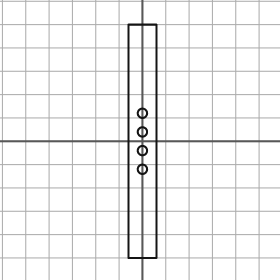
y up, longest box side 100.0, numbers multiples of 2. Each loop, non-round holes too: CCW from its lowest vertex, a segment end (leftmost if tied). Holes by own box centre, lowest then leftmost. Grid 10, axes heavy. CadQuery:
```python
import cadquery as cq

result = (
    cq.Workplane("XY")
    .moveTo(-6.0, -50.0)
    .lineTo(6.0, -50.0)
    .lineTo(6.0, 50.0)
    .lineTo(-6.0, 50.0)
    .close()
    .moveTo(0.0, -12.0)
    .circle(2.0)
    .moveTo(0.0, -4.0)
    .circle(2.0)
    .moveTo(0.0, 4.0)
    .circle(2.0)
    .moveTo(0.0, 12.0)
    .circle(2.0)
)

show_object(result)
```